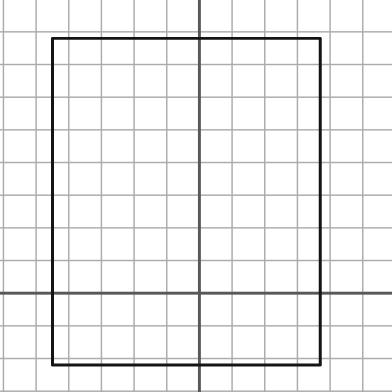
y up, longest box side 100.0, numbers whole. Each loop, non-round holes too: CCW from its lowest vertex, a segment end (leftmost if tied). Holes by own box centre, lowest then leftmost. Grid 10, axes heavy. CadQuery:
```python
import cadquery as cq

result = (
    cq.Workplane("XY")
    .moveTo(-45.0, -22.0)
    .lineTo(37.0, -22.0)
    .lineTo(37.0, 78.0)
    .lineTo(-45.0, 78.0)
    .close()
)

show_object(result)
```